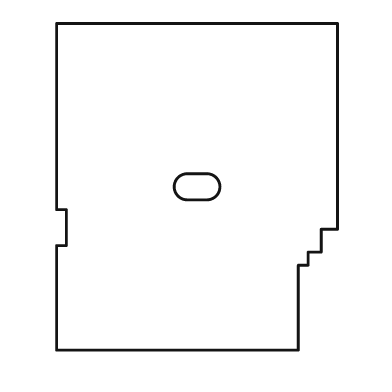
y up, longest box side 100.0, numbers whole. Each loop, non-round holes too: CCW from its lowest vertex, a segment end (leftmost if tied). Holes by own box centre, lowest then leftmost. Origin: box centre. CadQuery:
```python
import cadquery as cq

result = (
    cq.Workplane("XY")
    .moveTo(-43.0, -50.0)
    .lineTo(31.0, -50.0)
    .lineTo(31.0, -24.0)
    .lineTo(34.0, -24.0)
    .lineTo(34.0, -20.0)
    .lineTo(38.0, -20.0)
    .lineTo(38.0, -13.0)
    .lineTo(43.0, -13.0)
    .lineTo(43.0, 50.0)
    .lineTo(-43.0, 50.0)
    .lineTo(-43.0, -7.0)
    .lineTo(-40.0, -7.0)
    .lineTo(-40.0, -18.0)
    .lineTo(-43.0, -18.0)
    .close()
    .moveTo(-3.0, -4.0)
    .lineTo(3.0, -4.0)
    .threePointArc((7.0, 0.0), (3.0, 4.0))
    .lineTo(-3.0, 4.0)
    .threePointArc((-7.0, 0.0), (-3.0, -4.0))
    .close()
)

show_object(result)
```